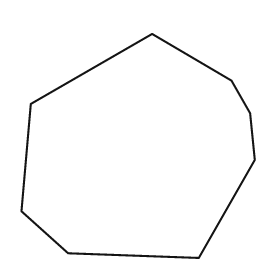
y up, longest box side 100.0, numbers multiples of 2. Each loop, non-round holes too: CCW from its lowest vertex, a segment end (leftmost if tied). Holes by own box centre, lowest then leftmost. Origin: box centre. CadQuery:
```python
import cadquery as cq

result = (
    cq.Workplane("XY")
    .moveTo(26.0, -48.0)
    .lineTo(50.0, -6.0)
    .lineTo(48.0, 14.0)
    .lineTo(40.0, 28.0)
    .lineTo(6.0, 48.0)
    .lineTo(-46.0, 18.0)
    .lineTo(-50.0, -28.0)
    .lineTo(-30.0, -46.0)
    .close()
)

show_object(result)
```